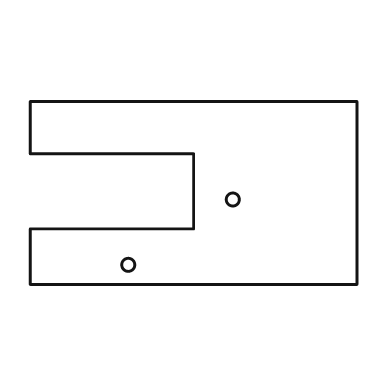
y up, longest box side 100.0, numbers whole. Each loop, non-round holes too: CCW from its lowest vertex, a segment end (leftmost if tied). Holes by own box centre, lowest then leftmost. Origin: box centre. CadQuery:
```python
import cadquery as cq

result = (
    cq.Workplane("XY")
    .moveTo(-50.0, -28.0)
    .lineTo(50.0, -28.0)
    .lineTo(50.0, 28.0)
    .lineTo(-50.0, 28.0)
    .lineTo(-50.0, 12.0)
    .lineTo(0.0, 12.0)
    .lineTo(0.0, -11.0)
    .lineTo(-50.0, -11.0)
    .close()
    .moveTo(-20.0, -22.0)
    .circle(2.0)
    .moveTo(12.0, -2.0)
    .circle(2.0)
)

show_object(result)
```